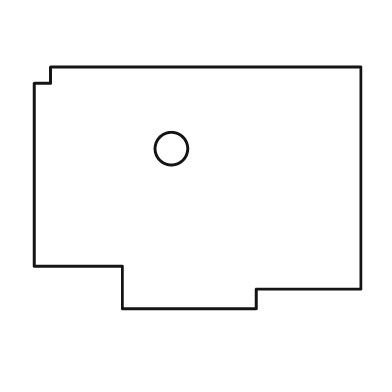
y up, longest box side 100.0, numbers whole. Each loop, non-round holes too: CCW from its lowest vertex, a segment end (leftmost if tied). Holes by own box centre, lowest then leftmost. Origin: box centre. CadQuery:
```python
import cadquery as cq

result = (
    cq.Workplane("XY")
    .moveTo(-23.0, -37.0)
    .lineTo(18.0, -37.0)
    .lineTo(18.0, -31.0)
    .lineTo(50.0, -31.0)
    .lineTo(50.0, 37.0)
    .lineTo(-45.0, 37.0)
    .lineTo(-45.0, 32.0)
    .lineTo(-50.0, 32.0)
    .lineTo(-50.0, -24.0)
    .lineTo(-23.0, -24.0)
    .close()
    .moveTo(-8.0, 12.0)
    .circle(5.0)
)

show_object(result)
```